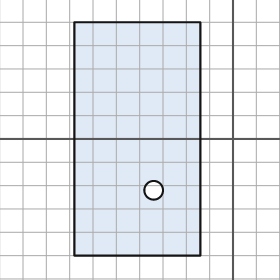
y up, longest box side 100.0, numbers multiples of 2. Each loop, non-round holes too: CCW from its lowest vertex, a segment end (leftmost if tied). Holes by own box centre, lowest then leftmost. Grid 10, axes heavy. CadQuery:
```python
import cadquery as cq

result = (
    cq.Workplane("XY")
    .moveTo(-68.0, -50.0)
    .lineTo(-14.0, -50.0)
    .lineTo(-14.0, 50.0)
    .lineTo(-68.0, 50.0)
    .close()
    .moveTo(-34.0, -22.0)
    .circle(4.0)
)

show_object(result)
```